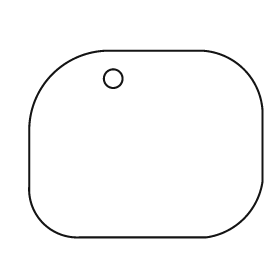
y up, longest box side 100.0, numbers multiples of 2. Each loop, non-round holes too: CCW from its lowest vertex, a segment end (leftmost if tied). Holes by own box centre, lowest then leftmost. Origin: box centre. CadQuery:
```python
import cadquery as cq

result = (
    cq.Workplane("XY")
    .moveTo(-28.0, -40.0)
    .lineTo(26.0, -40.0)
    .threePointArc((42.0, -32.0), (50.0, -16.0))
    .lineTo(50.0, 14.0)
    .threePointArc((42.0, 32.0), (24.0, 40.0))
    .lineTo(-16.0, 40.0)
    .threePointArc((-40.0, 30.0), (-50.0, 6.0))
    .lineTo(-50.0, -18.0)
    .threePointArc((-44.0, -34.0), (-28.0, -40.0))
    .close()
    .moveTo(-14.0, 28.0)
    .circle(4.0)
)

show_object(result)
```